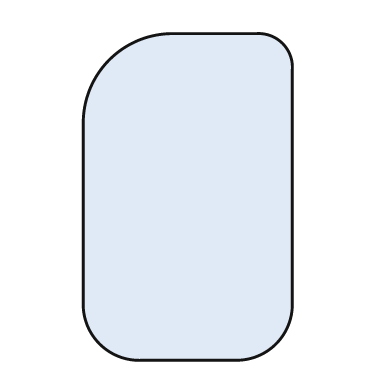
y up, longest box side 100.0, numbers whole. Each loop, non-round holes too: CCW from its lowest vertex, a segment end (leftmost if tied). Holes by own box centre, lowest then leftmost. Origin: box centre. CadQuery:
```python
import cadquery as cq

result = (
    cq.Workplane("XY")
    .moveTo(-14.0, -50.0)
    .lineTo(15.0, -50.0)
    .threePointArc((27.0, -45.0), (32.0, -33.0))
    .lineTo(32.0, 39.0)
    .threePointArc((29.0, 47.0), (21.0, 50.0))
    .lineTo(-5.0, 50.0)
    .threePointArc((-24.0, 42.0), (-32.0, 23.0))
    .lineTo(-32.0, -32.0)
    .threePointArc((-27.0, -45.0), (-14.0, -50.0))
    .close()
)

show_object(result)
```